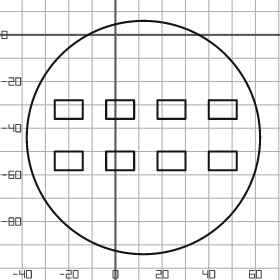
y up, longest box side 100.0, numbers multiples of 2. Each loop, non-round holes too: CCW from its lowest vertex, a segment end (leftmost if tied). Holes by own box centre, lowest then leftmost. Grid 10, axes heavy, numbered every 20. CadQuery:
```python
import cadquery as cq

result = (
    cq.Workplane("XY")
    .moveTo(12.0, -44.0)
    .circle(50.0)
    .moveTo(-26.0, -58.0)
    .lineTo(-14.0, -58.0)
    .lineTo(-14.0, -50.0)
    .lineTo(-26.0, -50.0)
    .close()
    .moveTo(-4.0, -58.0)
    .lineTo(8.0, -58.0)
    .lineTo(8.0, -50.0)
    .lineTo(-4.0, -50.0)
    .close()
    .moveTo(18.0, -58.0)
    .lineTo(30.0, -58.0)
    .lineTo(30.0, -50.0)
    .lineTo(18.0, -50.0)
    .close()
    .moveTo(40.0, -58.0)
    .lineTo(52.0, -58.0)
    .lineTo(52.0, -50.0)
    .lineTo(40.0, -50.0)
    .close()
    .moveTo(-26.0, -36.0)
    .lineTo(-14.0, -36.0)
    .lineTo(-14.0, -28.0)
    .lineTo(-26.0, -28.0)
    .close()
    .moveTo(-4.0, -36.0)
    .lineTo(8.0, -36.0)
    .lineTo(8.0, -28.0)
    .lineTo(-4.0, -28.0)
    .close()
    .moveTo(18.0, -36.0)
    .lineTo(30.0, -36.0)
    .lineTo(30.0, -28.0)
    .lineTo(18.0, -28.0)
    .close()
    .moveTo(40.0, -36.0)
    .lineTo(52.0, -36.0)
    .lineTo(52.0, -28.0)
    .lineTo(40.0, -28.0)
    .close()
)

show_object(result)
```